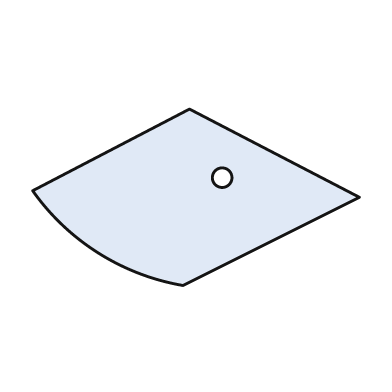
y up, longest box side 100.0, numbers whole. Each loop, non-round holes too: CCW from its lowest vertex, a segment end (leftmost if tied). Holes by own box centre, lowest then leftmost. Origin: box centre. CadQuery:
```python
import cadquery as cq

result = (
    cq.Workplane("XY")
    .moveTo(-4.0, -27.0)
    .lineTo(50.0, 0.0)
    .lineTo(-2.0, 27.0)
    .lineTo(-50.0, 2.0)
    .threePointArc((-30.0, -17.0), (-4.0, -27.0))
    .close()
    .moveTo(8.0, 6.0)
    .circle(3.0)
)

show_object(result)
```